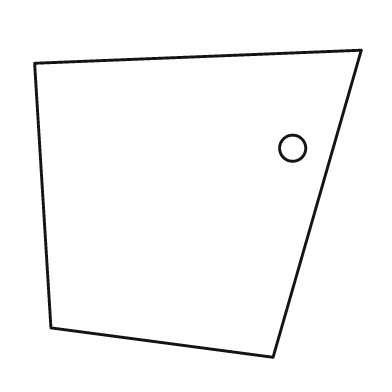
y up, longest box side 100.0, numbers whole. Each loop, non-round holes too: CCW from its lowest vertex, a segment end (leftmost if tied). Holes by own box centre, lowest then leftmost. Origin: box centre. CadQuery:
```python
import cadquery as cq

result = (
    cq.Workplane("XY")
    .moveTo(23.0, -47.0)
    .lineTo(50.0, 47.0)
    .lineTo(-50.0, 43.0)
    .lineTo(-45.0, -38.0)
    .close()
    .moveTo(29.0, 17.0)
    .circle(4.0)
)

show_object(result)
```